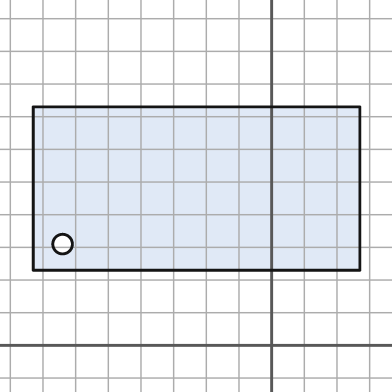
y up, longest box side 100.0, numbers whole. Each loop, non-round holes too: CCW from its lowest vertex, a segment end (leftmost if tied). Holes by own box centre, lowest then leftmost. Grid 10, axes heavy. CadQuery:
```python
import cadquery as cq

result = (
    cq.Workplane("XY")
    .moveTo(-73.0, 23.0)
    .lineTo(27.0, 23.0)
    .lineTo(27.0, 73.0)
    .lineTo(-73.0, 73.0)
    .close()
    .moveTo(-64.0, 31.0)
    .circle(3.0)
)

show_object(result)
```